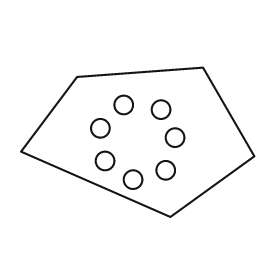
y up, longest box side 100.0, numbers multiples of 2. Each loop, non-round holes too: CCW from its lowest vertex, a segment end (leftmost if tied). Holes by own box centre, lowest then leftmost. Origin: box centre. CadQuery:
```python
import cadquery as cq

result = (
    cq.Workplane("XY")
    .moveTo(14.0, -32.0)
    .lineTo(50.0, -6.0)
    .lineTo(28.0, 32.0)
    .lineTo(-26.0, 28.0)
    .lineTo(-50.0, -4.0)
    .close()
    .moveTo(-2.0, -16.0)
    .circle(4.0)
    .moveTo(12.0, -12.0)
    .circle(4.0)
    .moveTo(-14.0, -8.0)
    .circle(4.0)
    .moveTo(16.0, 2.0)
    .circle(4.0)
    .moveTo(-16.0, 6.0)
    .circle(4.0)
    .moveTo(10.0, 14.0)
    .circle(4.0)
    .moveTo(-6.0, 16.0)
    .circle(4.0)
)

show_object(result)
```